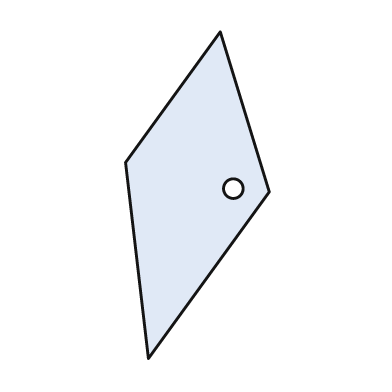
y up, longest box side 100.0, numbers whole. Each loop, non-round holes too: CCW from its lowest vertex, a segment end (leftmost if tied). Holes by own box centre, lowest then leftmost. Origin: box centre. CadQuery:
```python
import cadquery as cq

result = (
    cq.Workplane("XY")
    .moveTo(-15.0, -50.0)
    .lineTo(22.0, 1.0)
    .lineTo(7.0, 50.0)
    .lineTo(-22.0, 10.0)
    .close()
    .moveTo(11.0, 2.0)
    .circle(3.0)
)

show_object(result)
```